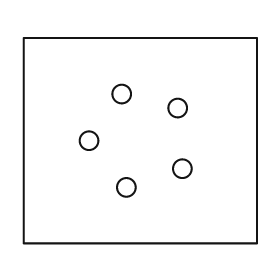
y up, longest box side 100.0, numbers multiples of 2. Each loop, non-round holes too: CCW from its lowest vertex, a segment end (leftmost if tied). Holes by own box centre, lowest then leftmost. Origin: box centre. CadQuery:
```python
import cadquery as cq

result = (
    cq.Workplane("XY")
    .moveTo(-50.0, -44.0)
    .lineTo(50.0, -44.0)
    .lineTo(50.0, 44.0)
    .lineTo(-50.0, 44.0)
    .close()
    .moveTo(-6.0, -20.0)
    .circle(4.0)
    .moveTo(18.0, -12.0)
    .circle(4.0)
    .moveTo(-22.0, 0.0)
    .circle(4.0)
    .moveTo(16.0, 14.0)
    .circle(4.0)
    .moveTo(-8.0, 20.0)
    .circle(4.0)
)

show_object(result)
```